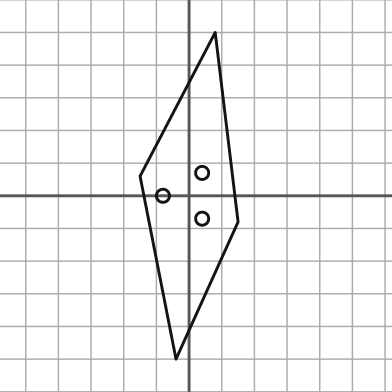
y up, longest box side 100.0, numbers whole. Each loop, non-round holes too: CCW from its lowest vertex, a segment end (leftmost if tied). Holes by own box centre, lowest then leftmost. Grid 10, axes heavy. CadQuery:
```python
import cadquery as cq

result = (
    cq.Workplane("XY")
    .moveTo(-4.0, -50.0)
    .lineTo(15.0, -8.0)
    .lineTo(8.0, 50.0)
    .lineTo(-15.0, 6.0)
    .close()
    .moveTo(4.0, -7.0)
    .circle(2.0)
    .moveTo(-8.0, 0.0)
    .circle(2.0)
    .moveTo(4.0, 7.0)
    .circle(2.0)
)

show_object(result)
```